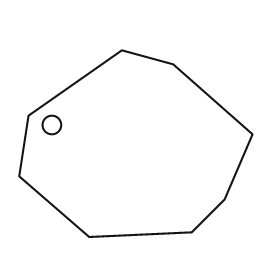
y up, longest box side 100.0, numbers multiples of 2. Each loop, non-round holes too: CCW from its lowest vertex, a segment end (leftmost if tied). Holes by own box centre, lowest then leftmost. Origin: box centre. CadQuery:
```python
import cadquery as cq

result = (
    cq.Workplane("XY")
    .moveTo(-20.0, -40.0)
    .lineTo(24.0, -38.0)
    .lineTo(38.0, -24.0)
    .lineTo(50.0, 4.0)
    .lineTo(16.0, 34.0)
    .lineTo(-6.0, 40.0)
    .lineTo(-46.0, 12.0)
    .lineTo(-50.0, -14.0)
    .close()
    .moveTo(-36.0, 8.0)
    .circle(4.0)
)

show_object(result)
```